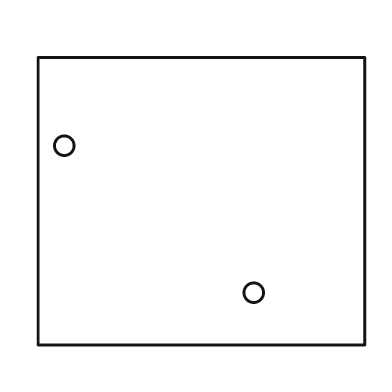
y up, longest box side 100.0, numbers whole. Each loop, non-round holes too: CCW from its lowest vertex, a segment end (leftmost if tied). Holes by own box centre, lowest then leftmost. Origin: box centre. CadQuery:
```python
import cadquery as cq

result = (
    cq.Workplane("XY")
    .moveTo(-50.0, -44.0)
    .lineTo(50.0, -44.0)
    .lineTo(50.0, 44.0)
    .lineTo(-50.0, 44.0)
    .close()
    .moveTo(16.0, -28.0)
    .circle(3.0)
    .moveTo(-42.0, 17.0)
    .circle(3.0)
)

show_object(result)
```